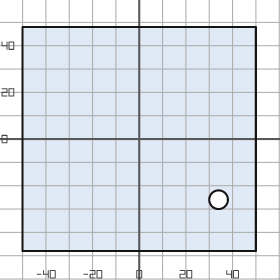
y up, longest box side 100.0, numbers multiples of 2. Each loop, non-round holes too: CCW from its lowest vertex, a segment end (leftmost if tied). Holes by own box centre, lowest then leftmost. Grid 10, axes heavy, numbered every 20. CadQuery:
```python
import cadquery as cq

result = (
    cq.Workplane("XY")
    .moveTo(-50.0, -48.0)
    .lineTo(50.0, -48.0)
    .lineTo(50.0, 48.0)
    .lineTo(-50.0, 48.0)
    .close()
    .moveTo(34.0, -26.0)
    .circle(4.0)
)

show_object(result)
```